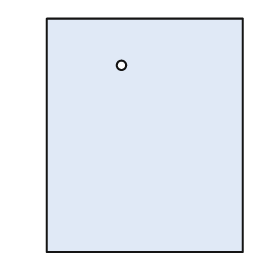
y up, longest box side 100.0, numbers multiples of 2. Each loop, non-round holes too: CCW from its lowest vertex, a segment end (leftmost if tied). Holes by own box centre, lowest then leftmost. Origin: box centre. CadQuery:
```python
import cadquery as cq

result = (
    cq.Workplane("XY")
    .moveTo(-42.0, -50.0)
    .lineTo(42.0, -50.0)
    .lineTo(42.0, 50.0)
    .lineTo(-42.0, 50.0)
    .close()
    .moveTo(-10.0, 30.0)
    .circle(2.0)
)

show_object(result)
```